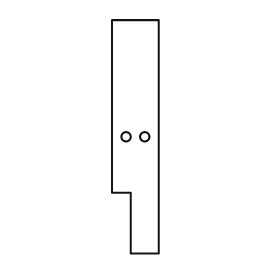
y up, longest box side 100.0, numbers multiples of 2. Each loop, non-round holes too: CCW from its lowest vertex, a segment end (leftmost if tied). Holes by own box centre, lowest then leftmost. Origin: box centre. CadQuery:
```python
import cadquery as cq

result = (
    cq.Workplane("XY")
    .moveTo(-2.0, -50.0)
    .lineTo(10.0, -50.0)
    .lineTo(10.0, 50.0)
    .lineTo(-10.0, 50.0)
    .lineTo(-10.0, -24.0)
    .lineTo(-2.0, -24.0)
    .close()
    .moveTo(-4.0, 0.0)
    .circle(2.0)
    .moveTo(4.0, 0.0)
    .circle(2.0)
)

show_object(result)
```